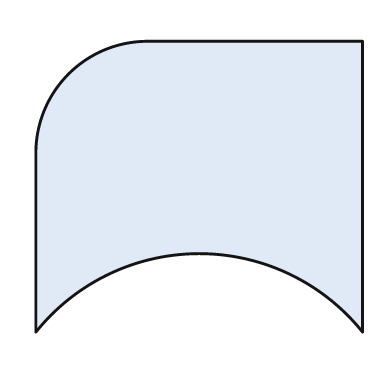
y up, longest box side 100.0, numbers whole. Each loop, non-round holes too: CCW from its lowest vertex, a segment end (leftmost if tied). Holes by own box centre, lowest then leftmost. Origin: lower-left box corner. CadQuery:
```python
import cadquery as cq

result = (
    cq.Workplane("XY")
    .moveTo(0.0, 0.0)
    .threePointArc((50.0, 24.0), (100.0, 0.0))
    .lineTo(100.0, 89.0)
    .lineTo(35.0, 89.0)
    .threePointArc((10.0, 79.0), (0.0, 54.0))
    .close()
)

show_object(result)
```